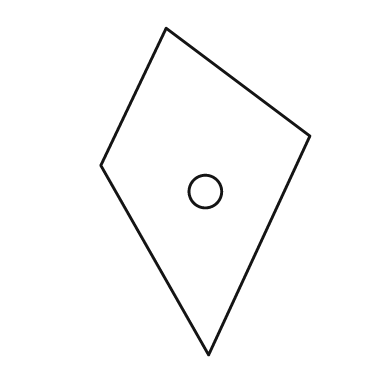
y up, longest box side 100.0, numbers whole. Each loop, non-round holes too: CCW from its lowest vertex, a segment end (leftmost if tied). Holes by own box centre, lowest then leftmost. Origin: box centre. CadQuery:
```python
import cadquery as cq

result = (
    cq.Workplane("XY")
    .moveTo(1.0, -50.0)
    .lineTo(32.0, 17.0)
    .lineTo(-12.0, 50.0)
    .lineTo(-32.0, 8.0)
    .close()
    .moveTo(0.0, 0.0)
    .circle(5.0)
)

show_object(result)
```